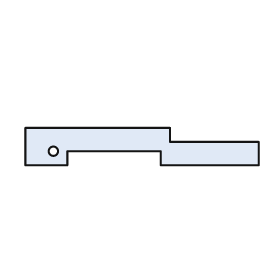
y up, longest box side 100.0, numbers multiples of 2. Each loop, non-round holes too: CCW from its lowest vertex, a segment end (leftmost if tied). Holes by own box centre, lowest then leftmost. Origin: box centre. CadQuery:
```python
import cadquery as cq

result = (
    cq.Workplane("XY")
    .moveTo(-50.0, -8.0)
    .lineTo(-32.0, -8.0)
    .lineTo(-32.0, -2.0)
    .lineTo(8.0, -2.0)
    .lineTo(8.0, -8.0)
    .lineTo(50.0, -8.0)
    .lineTo(50.0, 2.0)
    .lineTo(12.0, 2.0)
    .lineTo(12.0, 8.0)
    .lineTo(-50.0, 8.0)
    .close()
    .moveTo(-38.0, -2.0)
    .circle(2.0)
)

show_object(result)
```